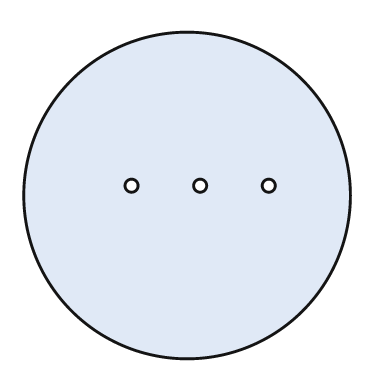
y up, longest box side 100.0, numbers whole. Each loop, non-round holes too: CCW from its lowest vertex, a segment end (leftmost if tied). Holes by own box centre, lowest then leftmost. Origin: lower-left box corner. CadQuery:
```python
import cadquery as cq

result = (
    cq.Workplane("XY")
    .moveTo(50.0, 50.0)
    .circle(50.0)
    .moveTo(33.0, 53.0)
    .circle(2.0)
    .moveTo(54.0, 53.0)
    .circle(2.0)
    .moveTo(75.0, 53.0)
    .circle(2.0)
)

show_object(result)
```